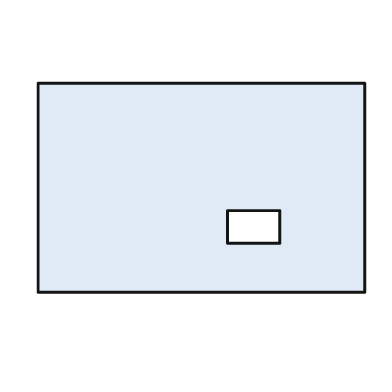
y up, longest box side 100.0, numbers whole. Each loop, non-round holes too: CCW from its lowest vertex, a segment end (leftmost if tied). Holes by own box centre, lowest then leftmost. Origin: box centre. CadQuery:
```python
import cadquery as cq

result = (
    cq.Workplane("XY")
    .moveTo(-50.0, -32.0)
    .lineTo(50.0, -32.0)
    .lineTo(50.0, 32.0)
    .lineTo(-50.0, 32.0)
    .close()
    .moveTo(8.0, -17.0)
    .lineTo(24.0, -17.0)
    .lineTo(24.0, -7.0)
    .lineTo(8.0, -7.0)
    .close()
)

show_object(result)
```